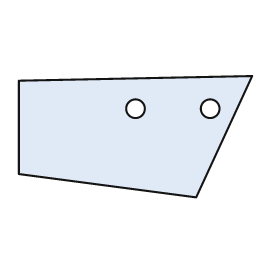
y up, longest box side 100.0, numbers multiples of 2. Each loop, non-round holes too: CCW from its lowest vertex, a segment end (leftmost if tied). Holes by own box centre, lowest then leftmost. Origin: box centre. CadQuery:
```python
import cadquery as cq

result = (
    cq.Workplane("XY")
    .moveTo(26.0, -26.0)
    .lineTo(50.0, 26.0)
    .lineTo(-50.0, 24.0)
    .lineTo(-50.0, -16.0)
    .close()
    .moveTo(0.0, 12.0)
    .circle(4.0)
    .moveTo(32.0, 12.0)
    .circle(4.0)
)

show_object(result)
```